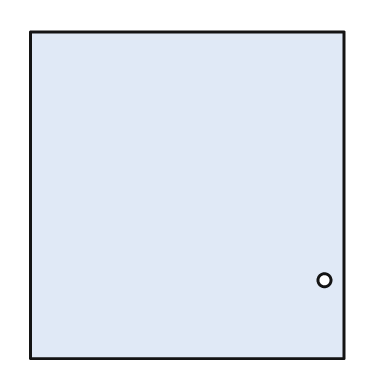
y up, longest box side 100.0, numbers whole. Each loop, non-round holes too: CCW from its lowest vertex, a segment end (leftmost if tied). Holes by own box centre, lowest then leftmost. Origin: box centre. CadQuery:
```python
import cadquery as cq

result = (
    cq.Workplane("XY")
    .moveTo(-48.0, -50.0)
    .lineTo(48.0, -50.0)
    .lineTo(48.0, 50.0)
    .lineTo(-48.0, 50.0)
    .close()
    .moveTo(42.0, -26.0)
    .circle(2.0)
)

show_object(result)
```